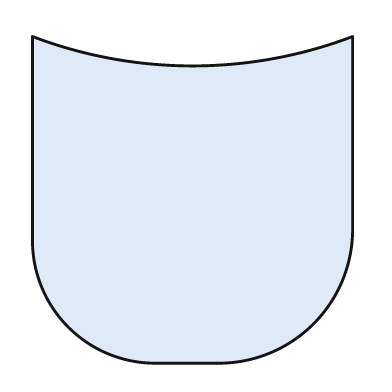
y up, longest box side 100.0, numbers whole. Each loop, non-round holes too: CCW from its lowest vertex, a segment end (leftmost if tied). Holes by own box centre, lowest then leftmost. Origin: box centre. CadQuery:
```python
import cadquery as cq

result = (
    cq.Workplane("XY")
    .moveTo(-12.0, -50.0)
    .lineTo(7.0, -50.0)
    .threePointArc((37.0, -38.0), (49.0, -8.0))
    .lineTo(49.0, 50.0)
    .threePointArc((0.0, 41.0), (-49.0, 50.0))
    .lineTo(-49.0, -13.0)
    .threePointArc((-38.0, -39.0), (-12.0, -50.0))
    .close()
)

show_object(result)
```